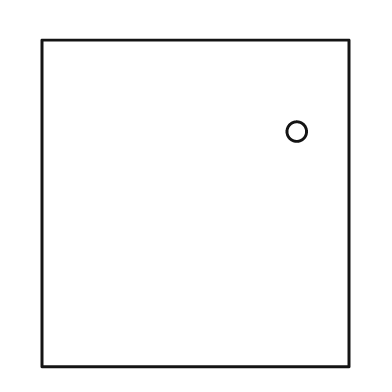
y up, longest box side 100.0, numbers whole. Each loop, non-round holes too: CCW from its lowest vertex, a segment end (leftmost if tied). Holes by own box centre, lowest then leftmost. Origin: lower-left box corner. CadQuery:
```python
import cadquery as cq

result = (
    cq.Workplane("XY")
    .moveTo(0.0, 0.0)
    .lineTo(94.0, 0.0)
    .lineTo(94.0, 100.0)
    .lineTo(0.0, 100.0)
    .close()
    .moveTo(78.0, 72.0)
    .circle(3.0)
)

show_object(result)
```